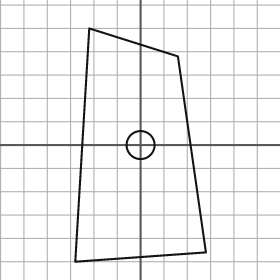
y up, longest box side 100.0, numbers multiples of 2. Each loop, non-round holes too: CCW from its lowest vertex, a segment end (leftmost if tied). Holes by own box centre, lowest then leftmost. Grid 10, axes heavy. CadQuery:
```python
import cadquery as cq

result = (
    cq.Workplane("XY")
    .moveTo(-28.0, -50.0)
    .lineTo(28.0, -46.0)
    .lineTo(16.0, 38.0)
    .lineTo(-22.0, 50.0)
    .close()
    .moveTo(0.0, 0.0)
    .circle(6.0)
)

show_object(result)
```